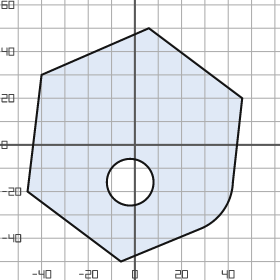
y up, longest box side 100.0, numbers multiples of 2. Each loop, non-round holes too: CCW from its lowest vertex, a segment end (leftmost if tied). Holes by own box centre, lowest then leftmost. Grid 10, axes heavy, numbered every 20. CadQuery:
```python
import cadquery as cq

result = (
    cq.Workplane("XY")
    .moveTo(-6.0, -50.0)
    .lineTo(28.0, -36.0)
    .threePointArc((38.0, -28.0), (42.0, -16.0))
    .lineTo(46.0, 20.0)
    .lineTo(6.0, 50.0)
    .lineTo(-40.0, 30.0)
    .lineTo(-46.0, -20.0)
    .close()
    .moveTo(-2.0, -16.0)
    .circle(10.0)
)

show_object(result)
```